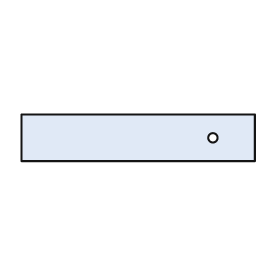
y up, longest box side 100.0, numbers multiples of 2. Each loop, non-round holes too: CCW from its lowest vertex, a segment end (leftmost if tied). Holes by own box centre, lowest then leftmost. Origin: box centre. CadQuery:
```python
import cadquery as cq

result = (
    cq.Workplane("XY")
    .moveTo(-50.0, -10.0)
    .lineTo(50.0, -10.0)
    .lineTo(50.0, 10.0)
    .lineTo(-50.0, 10.0)
    .close()
    .moveTo(32.0, 0.0)
    .circle(2.0)
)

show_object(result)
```